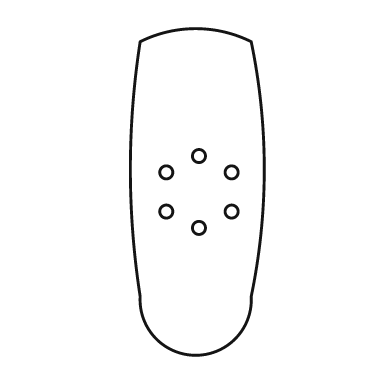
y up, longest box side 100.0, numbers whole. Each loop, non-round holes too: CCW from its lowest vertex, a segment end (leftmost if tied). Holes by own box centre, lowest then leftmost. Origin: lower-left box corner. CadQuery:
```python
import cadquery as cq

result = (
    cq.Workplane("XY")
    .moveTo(3.0, 18.0)
    .threePointArc((20.0, 0.0), (37.0, 18.0))
    .threePointArc((41.0, 57.0), (37.0, 96.0))
    .threePointArc((20.0, 100.0), (3.0, 96.0))
    .threePointArc((0.0, 57.0), (3.0, 18.0))
    .close()
    .moveTo(21.0, 39.0)
    .circle(2.0)
    .moveTo(11.0, 44.0)
    .circle(2.0)
    .moveTo(31.0, 44.0)
    .circle(2.0)
    .moveTo(11.0, 56.0)
    .circle(2.0)
    .moveTo(31.0, 56.0)
    .circle(2.0)
    .moveTo(21.0, 61.0)
    .circle(2.0)
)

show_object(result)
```